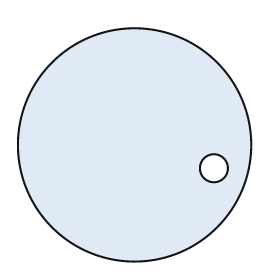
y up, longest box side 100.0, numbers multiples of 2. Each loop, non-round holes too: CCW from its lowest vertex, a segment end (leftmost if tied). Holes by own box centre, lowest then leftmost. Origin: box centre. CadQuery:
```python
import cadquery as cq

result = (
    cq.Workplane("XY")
    .moveTo(0.0, 0.0)
    .circle(50.0)
    .moveTo(34.0, -10.0)
    .circle(6.0)
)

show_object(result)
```